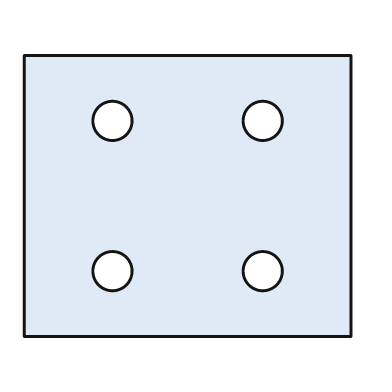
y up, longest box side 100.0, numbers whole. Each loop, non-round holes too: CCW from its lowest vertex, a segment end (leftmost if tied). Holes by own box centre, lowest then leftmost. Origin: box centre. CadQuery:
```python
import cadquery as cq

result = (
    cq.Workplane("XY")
    .moveTo(-50.0, -43.0)
    .lineTo(50.0, -43.0)
    .lineTo(50.0, 43.0)
    .lineTo(-50.0, 43.0)
    .close()
    .moveTo(-23.0, -23.0)
    .circle(6.0)
    .moveTo(23.0, -23.0)
    .circle(6.0)
    .moveTo(-23.0, 23.0)
    .circle(6.0)
    .moveTo(23.0, 23.0)
    .circle(6.0)
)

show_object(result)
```